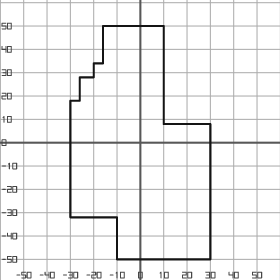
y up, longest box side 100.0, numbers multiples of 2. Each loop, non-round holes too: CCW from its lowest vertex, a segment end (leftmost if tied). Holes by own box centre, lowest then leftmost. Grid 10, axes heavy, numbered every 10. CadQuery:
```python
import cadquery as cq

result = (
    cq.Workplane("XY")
    .moveTo(-10.0, -50.0)
    .lineTo(30.0, -50.0)
    .lineTo(30.0, 8.0)
    .lineTo(10.0, 8.0)
    .lineTo(10.0, 50.0)
    .lineTo(-16.0, 50.0)
    .lineTo(-16.0, 34.0)
    .lineTo(-20.0, 34.0)
    .lineTo(-20.0, 28.0)
    .lineTo(-26.0, 28.0)
    .lineTo(-26.0, 18.0)
    .lineTo(-30.0, 18.0)
    .lineTo(-30.0, -32.0)
    .lineTo(-10.0, -32.0)
    .close()
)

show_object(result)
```